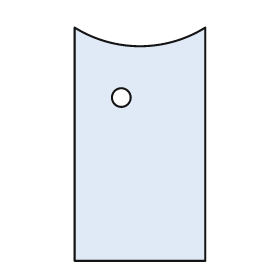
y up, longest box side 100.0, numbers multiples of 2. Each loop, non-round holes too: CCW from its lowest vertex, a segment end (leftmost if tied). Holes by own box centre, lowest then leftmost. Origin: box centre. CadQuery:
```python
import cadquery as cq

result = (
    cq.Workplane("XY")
    .moveTo(-28.0, -50.0)
    .lineTo(28.0, -50.0)
    .lineTo(28.0, 50.0)
    .threePointArc((0.0, 42.0), (-28.0, 50.0))
    .close()
    .moveTo(-8.0, 20.0)
    .circle(4.0)
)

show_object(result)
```